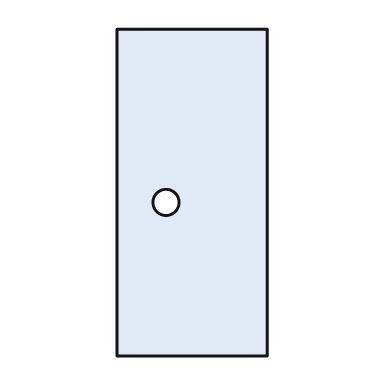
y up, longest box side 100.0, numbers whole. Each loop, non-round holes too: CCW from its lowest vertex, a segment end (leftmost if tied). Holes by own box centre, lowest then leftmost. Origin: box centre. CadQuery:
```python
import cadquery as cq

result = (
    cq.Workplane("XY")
    .moveTo(-23.0, -50.0)
    .lineTo(23.0, -50.0)
    .lineTo(23.0, 50.0)
    .lineTo(-23.0, 50.0)
    .close()
    .moveTo(-8.0, -3.0)
    .circle(4.0)
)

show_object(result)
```